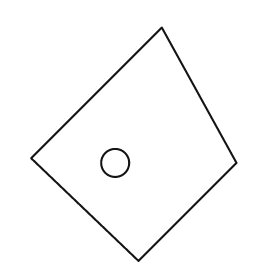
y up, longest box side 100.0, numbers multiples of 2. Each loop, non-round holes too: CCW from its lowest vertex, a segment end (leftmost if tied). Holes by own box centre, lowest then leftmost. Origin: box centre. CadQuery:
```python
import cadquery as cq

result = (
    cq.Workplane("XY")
    .moveTo(2.0, -50.0)
    .lineTo(44.0, -8.0)
    .lineTo(12.0, 50.0)
    .lineTo(-44.0, -6.0)
    .close()
    .moveTo(-8.0, -8.0)
    .circle(6.0)
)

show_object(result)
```